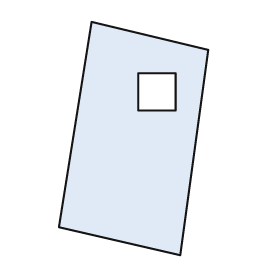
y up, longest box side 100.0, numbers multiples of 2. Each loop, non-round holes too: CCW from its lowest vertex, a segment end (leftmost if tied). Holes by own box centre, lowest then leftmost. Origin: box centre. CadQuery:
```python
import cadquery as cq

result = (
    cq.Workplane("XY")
    .moveTo(20.0, -50.0)
    .lineTo(32.0, 38.0)
    .lineTo(-18.0, 50.0)
    .lineTo(-32.0, -38.0)
    .close()
    .moveTo(2.0, 12.0)
    .lineTo(18.0, 12.0)
    .lineTo(18.0, 28.0)
    .lineTo(2.0, 28.0)
    .close()
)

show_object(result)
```